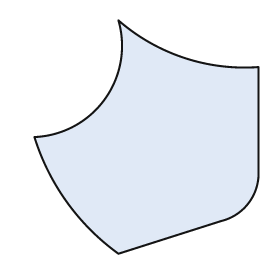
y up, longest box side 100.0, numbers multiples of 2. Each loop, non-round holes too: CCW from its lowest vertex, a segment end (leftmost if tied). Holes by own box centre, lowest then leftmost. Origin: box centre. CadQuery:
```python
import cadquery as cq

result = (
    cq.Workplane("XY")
    .moveTo(-12.0, -50.0)
    .lineTo(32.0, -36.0)
    .threePointArc((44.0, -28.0), (48.0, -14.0))
    .lineTo(48.0, 30.0)
    .threePointArc((16.0, 34.0), (-12.0, 50.0))
    .threePointArc((-18.0, 16.0), (-48.0, 0.0))
    .threePointArc((-34.0, -28.0), (-12.0, -50.0))
    .close()
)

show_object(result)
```